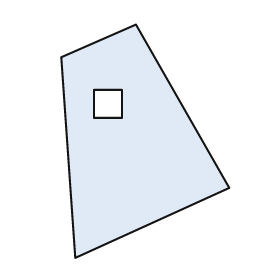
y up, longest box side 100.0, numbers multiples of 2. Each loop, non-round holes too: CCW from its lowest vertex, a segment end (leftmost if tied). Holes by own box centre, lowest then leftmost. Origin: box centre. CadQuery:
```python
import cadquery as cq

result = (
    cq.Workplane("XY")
    .moveTo(-30.0, -50.0)
    .lineTo(36.0, -20.0)
    .lineTo(-4.0, 50.0)
    .lineTo(-36.0, 36.0)
    .close()
    .moveTo(-22.0, 10.0)
    .lineTo(-10.0, 10.0)
    .lineTo(-10.0, 22.0)
    .lineTo(-22.0, 22.0)
    .close()
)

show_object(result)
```